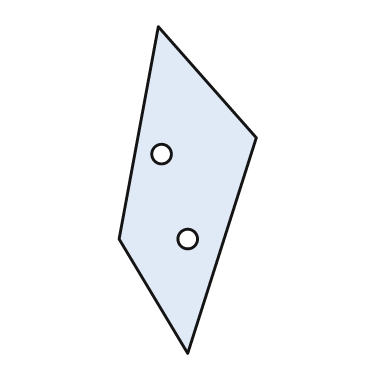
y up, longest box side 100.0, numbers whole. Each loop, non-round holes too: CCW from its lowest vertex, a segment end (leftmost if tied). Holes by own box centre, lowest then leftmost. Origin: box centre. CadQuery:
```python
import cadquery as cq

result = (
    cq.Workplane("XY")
    .moveTo(0.0, -50.0)
    .lineTo(21.0, 16.0)
    .lineTo(-9.0, 50.0)
    .lineTo(-21.0, -15.0)
    .close()
    .moveTo(0.0, -15.0)
    .circle(3.0)
    .moveTo(-8.0, 11.0)
    .circle(3.0)
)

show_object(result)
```